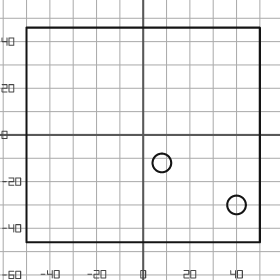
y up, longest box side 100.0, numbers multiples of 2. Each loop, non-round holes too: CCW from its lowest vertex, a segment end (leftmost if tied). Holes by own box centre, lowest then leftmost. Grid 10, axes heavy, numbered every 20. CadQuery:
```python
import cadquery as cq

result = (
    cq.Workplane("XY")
    .moveTo(-50.0, -46.0)
    .lineTo(50.0, -46.0)
    .lineTo(50.0, 46.0)
    .lineTo(-50.0, 46.0)
    .close()
    .moveTo(40.0, -30.0)
    .circle(4.0)
    .moveTo(8.0, -12.0)
    .circle(4.0)
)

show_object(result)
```